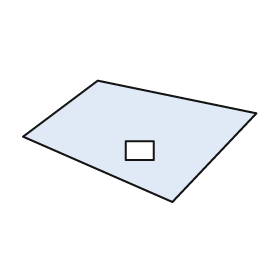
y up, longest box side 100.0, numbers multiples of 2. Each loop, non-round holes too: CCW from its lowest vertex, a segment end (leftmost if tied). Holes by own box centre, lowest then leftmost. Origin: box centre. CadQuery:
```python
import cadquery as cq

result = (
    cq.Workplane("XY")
    .moveTo(14.0, -26.0)
    .lineTo(50.0, 12.0)
    .lineTo(-18.0, 26.0)
    .lineTo(-50.0, 2.0)
    .close()
    .moveTo(-6.0, -8.0)
    .lineTo(6.0, -8.0)
    .lineTo(6.0, 0.0)
    .lineTo(-6.0, 0.0)
    .close()
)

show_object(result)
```